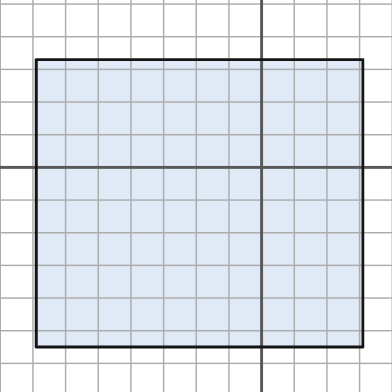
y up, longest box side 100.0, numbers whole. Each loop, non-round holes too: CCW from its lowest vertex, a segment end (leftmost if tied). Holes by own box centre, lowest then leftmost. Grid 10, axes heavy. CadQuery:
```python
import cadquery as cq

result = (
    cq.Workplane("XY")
    .moveTo(-69.0, -55.0)
    .lineTo(31.0, -55.0)
    .lineTo(31.0, 33.0)
    .lineTo(-69.0, 33.0)
    .close()
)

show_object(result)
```